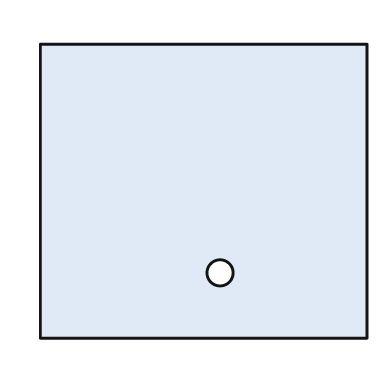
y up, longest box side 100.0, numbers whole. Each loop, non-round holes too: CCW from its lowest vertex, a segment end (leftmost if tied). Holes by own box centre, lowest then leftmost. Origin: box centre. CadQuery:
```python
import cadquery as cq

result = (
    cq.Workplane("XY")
    .moveTo(-50.0, -45.0)
    .lineTo(50.0, -45.0)
    .lineTo(50.0, 45.0)
    .lineTo(-50.0, 45.0)
    .close()
    .moveTo(5.0, -25.0)
    .circle(4.0)
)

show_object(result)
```